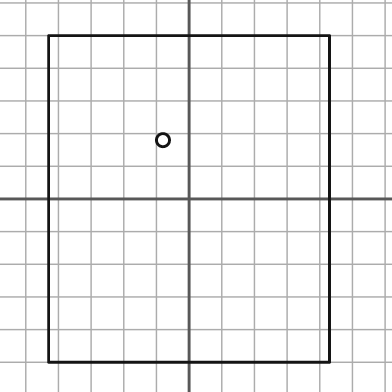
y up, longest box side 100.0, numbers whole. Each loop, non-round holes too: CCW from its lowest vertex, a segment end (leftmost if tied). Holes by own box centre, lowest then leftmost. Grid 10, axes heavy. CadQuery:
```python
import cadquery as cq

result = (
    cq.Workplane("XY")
    .moveTo(-43.0, -50.0)
    .lineTo(43.0, -50.0)
    .lineTo(43.0, 50.0)
    .lineTo(-43.0, 50.0)
    .close()
    .moveTo(-8.0, 18.0)
    .circle(2.0)
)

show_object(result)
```